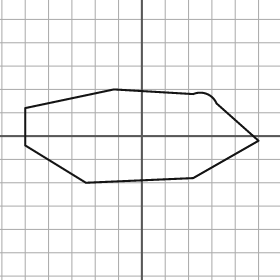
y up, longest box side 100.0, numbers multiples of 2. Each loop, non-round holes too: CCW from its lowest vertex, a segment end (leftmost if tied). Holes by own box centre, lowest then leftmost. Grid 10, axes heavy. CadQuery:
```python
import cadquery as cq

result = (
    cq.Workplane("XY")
    .moveTo(-24.0, -20.0)
    .lineTo(22.0, -18.0)
    .lineTo(50.0, -2.0)
    .lineTo(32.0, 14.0)
    .threePointArc((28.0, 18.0), (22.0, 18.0))
    .lineTo(-12.0, 20.0)
    .lineTo(-50.0, 12.0)
    .lineTo(-50.0, -4.0)
    .close()
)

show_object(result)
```